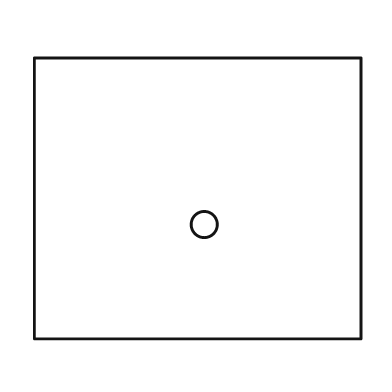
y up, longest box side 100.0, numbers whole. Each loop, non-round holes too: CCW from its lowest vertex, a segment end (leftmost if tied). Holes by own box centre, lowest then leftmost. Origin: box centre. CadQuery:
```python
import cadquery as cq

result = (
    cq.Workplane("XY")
    .moveTo(-50.0, -43.0)
    .lineTo(50.0, -43.0)
    .lineTo(50.0, 43.0)
    .lineTo(-50.0, 43.0)
    .close()
    .moveTo(2.0, -8.0)
    .circle(4.0)
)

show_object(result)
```